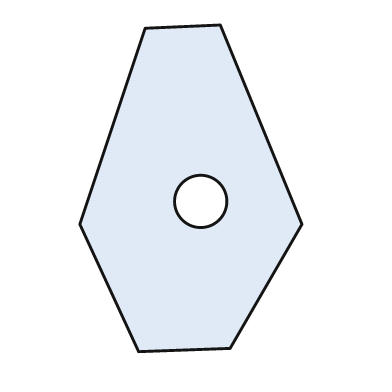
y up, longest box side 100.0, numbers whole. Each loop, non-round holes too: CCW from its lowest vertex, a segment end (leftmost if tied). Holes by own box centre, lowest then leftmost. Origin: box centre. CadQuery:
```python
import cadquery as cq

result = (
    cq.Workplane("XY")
    .moveTo(-16.0, -50.0)
    .lineTo(12.0, -49.0)
    .lineTo(34.0, -11.0)
    .lineTo(9.0, 50.0)
    .lineTo(-14.0, 49.0)
    .lineTo(-34.0, -11.0)
    .close()
    .moveTo(3.0, -4.0)
    .circle(8.0)
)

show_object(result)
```